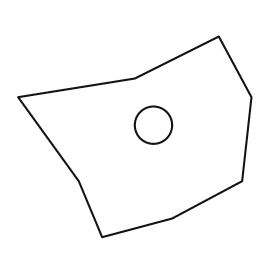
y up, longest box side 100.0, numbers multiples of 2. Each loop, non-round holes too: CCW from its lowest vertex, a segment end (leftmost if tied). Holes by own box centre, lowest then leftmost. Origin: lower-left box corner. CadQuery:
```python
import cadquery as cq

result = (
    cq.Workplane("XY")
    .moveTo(36.0, 0.0)
    .lineTo(66.0, 8.0)
    .lineTo(96.0, 24.0)
    .lineTo(100.0, 60.0)
    .lineTo(86.0, 86.0)
    .lineTo(50.0, 68.0)
    .lineTo(0.0, 60.0)
    .lineTo(26.0, 24.0)
    .close()
    .moveTo(58.0, 48.0)
    .circle(8.0)
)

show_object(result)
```